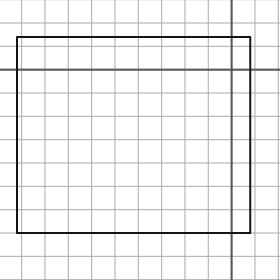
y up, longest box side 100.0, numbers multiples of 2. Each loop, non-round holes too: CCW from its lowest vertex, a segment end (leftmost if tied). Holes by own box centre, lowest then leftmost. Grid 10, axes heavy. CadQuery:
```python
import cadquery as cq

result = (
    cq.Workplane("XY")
    .moveTo(-92.0, -70.0)
    .lineTo(8.0, -70.0)
    .lineTo(8.0, 14.0)
    .lineTo(-92.0, 14.0)
    .close()
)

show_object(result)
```